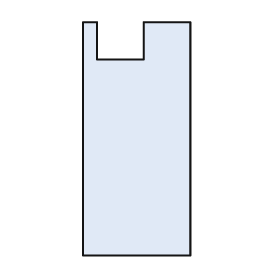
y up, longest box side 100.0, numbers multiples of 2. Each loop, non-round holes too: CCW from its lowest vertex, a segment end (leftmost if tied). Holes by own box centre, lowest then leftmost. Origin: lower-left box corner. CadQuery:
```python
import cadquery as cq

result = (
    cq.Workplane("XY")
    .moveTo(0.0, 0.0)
    .lineTo(46.0, 0.0)
    .lineTo(46.0, 100.0)
    .lineTo(26.0, 100.0)
    .lineTo(26.0, 84.0)
    .lineTo(6.0, 84.0)
    .lineTo(6.0, 100.0)
    .lineTo(0.0, 100.0)
    .close()
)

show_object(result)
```